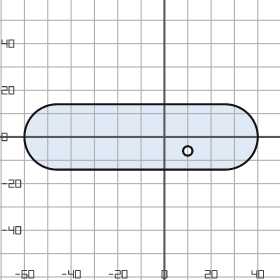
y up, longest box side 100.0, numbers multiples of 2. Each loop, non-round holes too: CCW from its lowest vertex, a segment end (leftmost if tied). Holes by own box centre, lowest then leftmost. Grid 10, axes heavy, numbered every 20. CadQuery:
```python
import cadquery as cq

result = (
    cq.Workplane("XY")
    .moveTo(-46.0, -14.0)
    .lineTo(26.0, -14.0)
    .threePointArc((40.0, 0.0), (26.0, 14.0))
    .lineTo(-46.0, 14.0)
    .threePointArc((-60.0, 0.0), (-46.0, -14.0))
    .close()
    .moveTo(10.0, -6.0)
    .circle(2.0)
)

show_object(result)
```